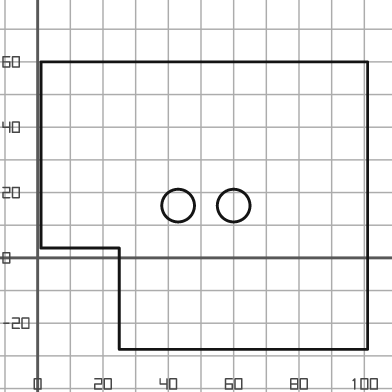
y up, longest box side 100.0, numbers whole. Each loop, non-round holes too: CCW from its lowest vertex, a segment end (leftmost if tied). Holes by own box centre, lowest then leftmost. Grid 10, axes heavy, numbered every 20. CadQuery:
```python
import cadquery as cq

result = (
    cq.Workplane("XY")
    .moveTo(25.0, -28.0)
    .lineTo(101.0, -28.0)
    .lineTo(101.0, 60.0)
    .lineTo(1.0, 60.0)
    .lineTo(1.0, 3.0)
    .lineTo(25.0, 3.0)
    .close()
    .moveTo(43.0, 16.0)
    .circle(5.0)
    .moveTo(60.0, 16.0)
    .circle(5.0)
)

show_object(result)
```